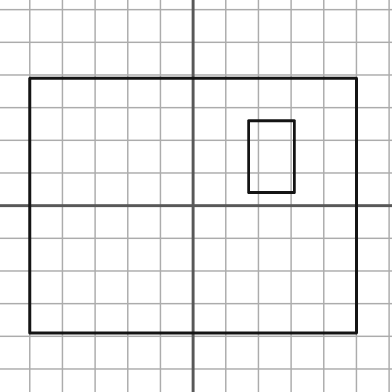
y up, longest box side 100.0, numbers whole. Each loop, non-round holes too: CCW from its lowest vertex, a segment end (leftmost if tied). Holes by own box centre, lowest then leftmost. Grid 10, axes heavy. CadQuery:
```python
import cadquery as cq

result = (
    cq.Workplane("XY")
    .moveTo(-50.0, -39.0)
    .lineTo(50.0, -39.0)
    .lineTo(50.0, 39.0)
    .lineTo(-50.0, 39.0)
    .close()
    .moveTo(17.0, 4.0)
    .lineTo(31.0, 4.0)
    .lineTo(31.0, 26.0)
    .lineTo(17.0, 26.0)
    .close()
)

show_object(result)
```